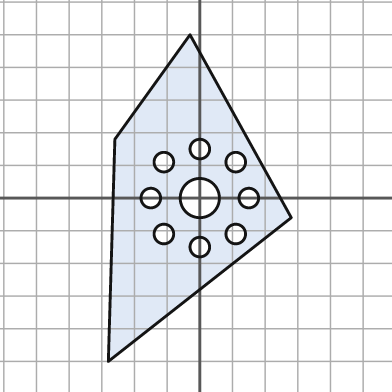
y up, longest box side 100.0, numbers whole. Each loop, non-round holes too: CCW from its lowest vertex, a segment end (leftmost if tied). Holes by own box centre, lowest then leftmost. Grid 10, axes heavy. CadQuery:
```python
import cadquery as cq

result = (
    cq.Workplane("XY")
    .moveTo(-28.0, -50.0)
    .lineTo(28.0, -6.0)
    .lineTo(-3.0, 50.0)
    .lineTo(-26.0, 18.0)
    .close()
    .moveTo(0.0, -15.0)
    .circle(3.0)
    .moveTo(-11.0, -11.0)
    .circle(3.0)
    .moveTo(11.0, -11.0)
    .circle(3.0)
    .moveTo(-15.0, 0.0)
    .circle(3.0)
    .moveTo(0.0, 0.0)
    .circle(6.0)
    .moveTo(15.0, 0.0)
    .circle(3.0)
    .moveTo(-11.0, 11.0)
    .circle(3.0)
    .moveTo(11.0, 11.0)
    .circle(3.0)
    .moveTo(0.0, 15.0)
    .circle(3.0)
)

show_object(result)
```